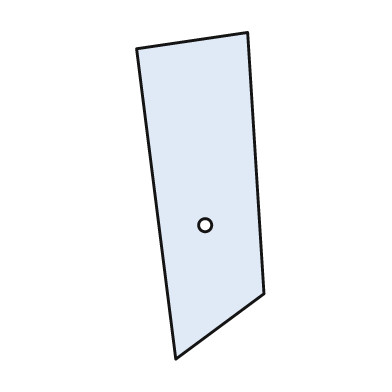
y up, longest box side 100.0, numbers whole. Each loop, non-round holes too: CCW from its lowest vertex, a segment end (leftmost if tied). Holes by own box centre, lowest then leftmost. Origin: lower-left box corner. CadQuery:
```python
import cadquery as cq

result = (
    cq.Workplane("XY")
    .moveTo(12.0, 0.0)
    .lineTo(39.0, 20.0)
    .lineTo(34.0, 100.0)
    .lineTo(0.0, 95.0)
    .close()
    .moveTo(21.0, 41.0)
    .circle(2.0)
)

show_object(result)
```